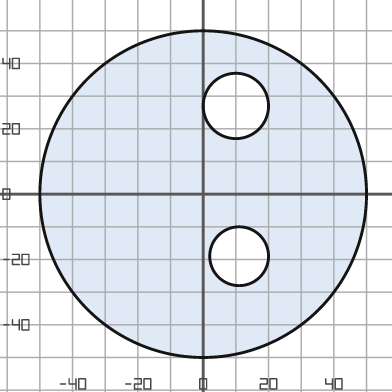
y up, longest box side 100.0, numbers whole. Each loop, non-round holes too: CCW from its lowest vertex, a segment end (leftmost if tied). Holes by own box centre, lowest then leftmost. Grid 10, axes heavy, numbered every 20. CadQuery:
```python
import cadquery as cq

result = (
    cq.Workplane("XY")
    .moveTo(0.0, 0.0)
    .circle(50.0)
    .moveTo(11.0, -19.0)
    .circle(9.0)
    .moveTo(10.0, 27.0)
    .circle(10.0)
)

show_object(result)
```